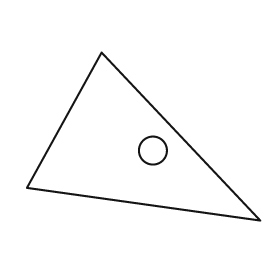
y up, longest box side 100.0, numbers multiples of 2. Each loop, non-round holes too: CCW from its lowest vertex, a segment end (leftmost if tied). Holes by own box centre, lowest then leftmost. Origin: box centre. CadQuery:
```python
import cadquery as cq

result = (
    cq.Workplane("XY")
    .moveTo(50.0, -36.0)
    .lineTo(-18.0, 36.0)
    .lineTo(-50.0, -22.0)
    .close()
    .moveTo(4.0, -6.0)
    .circle(6.0)
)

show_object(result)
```